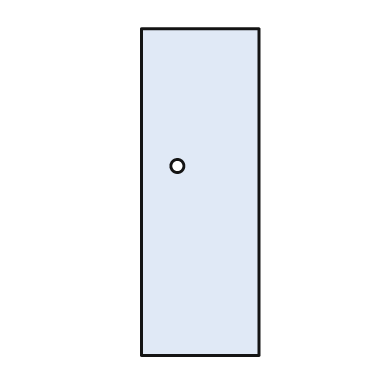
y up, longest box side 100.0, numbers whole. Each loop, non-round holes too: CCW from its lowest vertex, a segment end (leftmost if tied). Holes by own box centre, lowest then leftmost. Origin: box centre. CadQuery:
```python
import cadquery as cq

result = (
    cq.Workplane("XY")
    .moveTo(-18.0, -50.0)
    .lineTo(18.0, -50.0)
    .lineTo(18.0, 50.0)
    .lineTo(-18.0, 50.0)
    .close()
    .moveTo(-7.0, 8.0)
    .circle(2.0)
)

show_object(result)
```